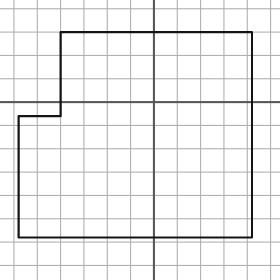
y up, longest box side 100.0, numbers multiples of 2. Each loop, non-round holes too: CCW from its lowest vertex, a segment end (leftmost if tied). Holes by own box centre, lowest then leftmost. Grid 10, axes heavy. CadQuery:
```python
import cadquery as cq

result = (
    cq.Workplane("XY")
    .moveTo(-58.0, -58.0)
    .lineTo(42.0, -58.0)
    .lineTo(42.0, 30.0)
    .lineTo(-40.0, 30.0)
    .lineTo(-40.0, -6.0)
    .lineTo(-58.0, -6.0)
    .close()
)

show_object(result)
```